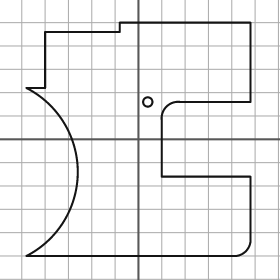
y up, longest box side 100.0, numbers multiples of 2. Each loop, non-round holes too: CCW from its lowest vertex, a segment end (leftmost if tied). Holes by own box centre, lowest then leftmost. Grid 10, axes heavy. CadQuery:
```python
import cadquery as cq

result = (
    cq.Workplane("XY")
    .moveTo(-48.0, -50.0)
    .lineTo(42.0, -50.0)
    .threePointArc((46.0, -48.0), (48.0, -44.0))
    .lineTo(48.0, -16.0)
    .lineTo(10.0, -16.0)
    .lineTo(10.0, 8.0)
    .threePointArc((12.0, 14.0), (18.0, 16.0))
    .lineTo(48.0, 16.0)
    .lineTo(48.0, 50.0)
    .lineTo(-8.0, 50.0)
    .lineTo(-8.0, 46.0)
    .lineTo(-40.0, 46.0)
    .lineTo(-40.0, 22.0)
    .lineTo(-48.0, 22.0)
    .threePointArc((-26.0, -14.0), (-48.0, -50.0))
    .close()
    .moveTo(4.0, 16.0)
    .circle(2.0)
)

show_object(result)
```